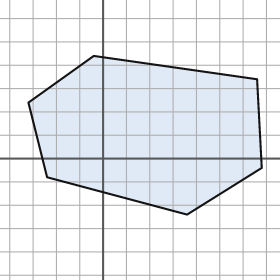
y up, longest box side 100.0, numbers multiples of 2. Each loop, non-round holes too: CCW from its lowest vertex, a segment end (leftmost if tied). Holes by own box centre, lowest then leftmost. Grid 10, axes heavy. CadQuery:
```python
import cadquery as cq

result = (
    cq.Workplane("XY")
    .moveTo(36.0, -24.0)
    .lineTo(68.0, -4.0)
    .lineTo(66.0, 34.0)
    .lineTo(-4.0, 44.0)
    .lineTo(-32.0, 24.0)
    .lineTo(-24.0, -8.0)
    .close()
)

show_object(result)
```